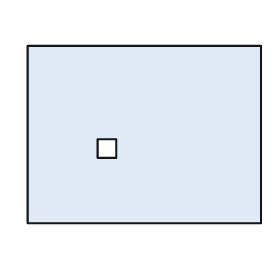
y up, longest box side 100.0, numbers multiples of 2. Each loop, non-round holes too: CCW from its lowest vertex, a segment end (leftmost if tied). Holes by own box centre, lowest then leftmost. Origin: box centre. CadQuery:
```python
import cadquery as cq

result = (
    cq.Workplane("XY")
    .moveTo(-50.0, -38.0)
    .lineTo(50.0, -38.0)
    .lineTo(50.0, 38.0)
    .lineTo(-50.0, 38.0)
    .close()
    .moveTo(-20.0, -10.0)
    .lineTo(-12.0, -10.0)
    .lineTo(-12.0, -2.0)
    .lineTo(-20.0, -2.0)
    .close()
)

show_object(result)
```